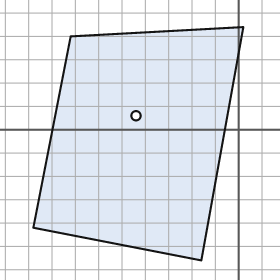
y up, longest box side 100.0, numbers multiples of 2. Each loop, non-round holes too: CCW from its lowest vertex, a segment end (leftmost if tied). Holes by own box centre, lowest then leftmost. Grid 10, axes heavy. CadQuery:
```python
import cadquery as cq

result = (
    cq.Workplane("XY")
    .moveTo(-16.0, -56.0)
    .lineTo(2.0, 44.0)
    .lineTo(-72.0, 40.0)
    .lineTo(-88.0, -42.0)
    .close()
    .moveTo(-44.0, 6.0)
    .circle(2.0)
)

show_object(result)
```